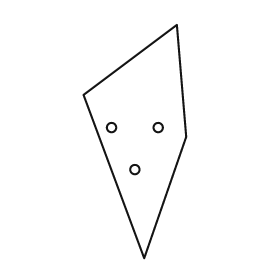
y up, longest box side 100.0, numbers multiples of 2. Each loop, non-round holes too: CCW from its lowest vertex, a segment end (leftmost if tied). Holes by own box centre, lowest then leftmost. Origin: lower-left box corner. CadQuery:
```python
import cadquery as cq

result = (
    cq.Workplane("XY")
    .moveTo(26.0, 0.0)
    .lineTo(44.0, 52.0)
    .lineTo(40.0, 100.0)
    .lineTo(0.0, 70.0)
    .close()
    .moveTo(22.0, 38.0)
    .circle(2.0)
    .moveTo(12.0, 56.0)
    .circle(2.0)
    .moveTo(32.0, 56.0)
    .circle(2.0)
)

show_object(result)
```